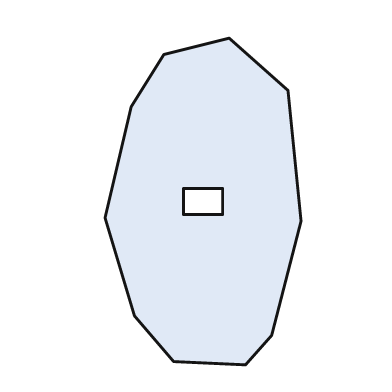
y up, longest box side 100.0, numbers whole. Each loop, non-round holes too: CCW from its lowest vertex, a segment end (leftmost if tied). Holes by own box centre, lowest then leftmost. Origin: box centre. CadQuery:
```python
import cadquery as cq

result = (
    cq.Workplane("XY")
    .moveTo(13.0, -50.0)
    .lineTo(21.0, -41.0)
    .lineTo(30.0, -6.0)
    .lineTo(26.0, 34.0)
    .lineTo(8.0, 50.0)
    .lineTo(-12.0, 45.0)
    .lineTo(-22.0, 29.0)
    .lineTo(-30.0, -5.0)
    .lineTo(-21.0, -35.0)
    .lineTo(-9.0, -49.0)
    .close()
    .moveTo(-6.0, -4.0)
    .lineTo(6.0, -4.0)
    .lineTo(6.0, 4.0)
    .lineTo(-6.0, 4.0)
    .close()
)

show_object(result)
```